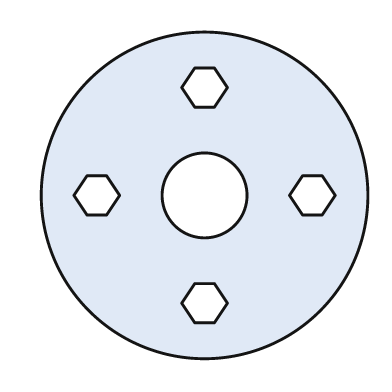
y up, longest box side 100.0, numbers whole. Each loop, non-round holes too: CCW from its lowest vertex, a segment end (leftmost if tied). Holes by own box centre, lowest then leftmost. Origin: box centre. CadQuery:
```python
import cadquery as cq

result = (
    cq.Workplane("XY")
    .moveTo(0.0, 0.0)
    .circle(50.0)
    .moveTo(-3.0, -39.0)
    .lineTo(3.0, -39.0)
    .lineTo(7.0, -33.0)
    .lineTo(3.0, -27.0)
    .lineTo(-3.0, -27.0)
    .lineTo(-7.0, -33.0)
    .close()
    .moveTo(-36.0, -6.0)
    .lineTo(-30.0, -6.0)
    .lineTo(-26.0, 0.0)
    .lineTo(-30.0, 6.0)
    .lineTo(-36.0, 6.0)
    .lineTo(-40.0, 0.0)
    .close()
    .moveTo(0.0, 0.0)
    .circle(13.0)
    .moveTo(30.0, -6.0)
    .lineTo(36.0, -6.0)
    .lineTo(40.0, 0.0)
    .lineTo(36.0, 6.0)
    .lineTo(30.0, 6.0)
    .lineTo(26.0, 0.0)
    .close()
    .moveTo(-3.0, 27.0)
    .lineTo(3.0, 27.0)
    .lineTo(7.0, 33.0)
    .lineTo(3.0, 39.0)
    .lineTo(-3.0, 39.0)
    .lineTo(-7.0, 33.0)
    .close()
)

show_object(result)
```